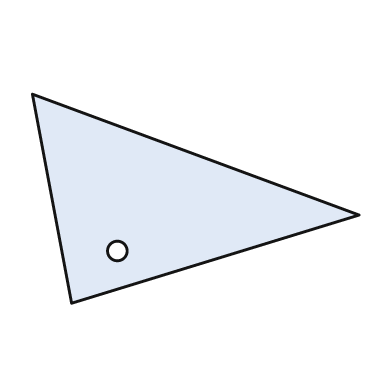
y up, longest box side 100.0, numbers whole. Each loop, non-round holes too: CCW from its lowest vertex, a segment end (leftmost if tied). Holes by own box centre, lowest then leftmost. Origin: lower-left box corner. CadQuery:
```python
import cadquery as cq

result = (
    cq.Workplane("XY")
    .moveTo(12.0, 0.0)
    .lineTo(100.0, 27.0)
    .lineTo(0.0, 64.0)
    .close()
    .moveTo(26.0, 16.0)
    .circle(3.0)
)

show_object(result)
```